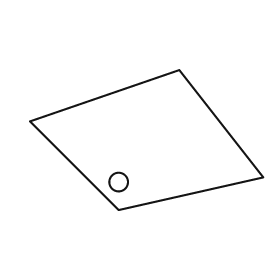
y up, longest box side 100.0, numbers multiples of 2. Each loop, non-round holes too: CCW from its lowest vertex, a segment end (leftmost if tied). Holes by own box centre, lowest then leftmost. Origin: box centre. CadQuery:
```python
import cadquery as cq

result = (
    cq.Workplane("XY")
    .moveTo(-12.0, -30.0)
    .lineTo(50.0, -16.0)
    .lineTo(14.0, 30.0)
    .lineTo(-50.0, 8.0)
    .close()
    .moveTo(-12.0, -18.0)
    .circle(4.0)
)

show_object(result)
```